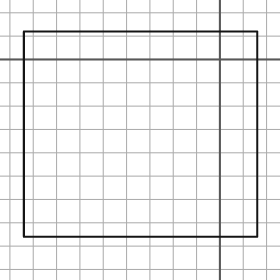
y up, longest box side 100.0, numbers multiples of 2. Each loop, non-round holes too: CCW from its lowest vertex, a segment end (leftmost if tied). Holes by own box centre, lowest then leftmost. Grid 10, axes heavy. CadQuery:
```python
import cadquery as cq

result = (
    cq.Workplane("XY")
    .moveTo(-84.0, -76.0)
    .lineTo(16.0, -76.0)
    .lineTo(16.0, 12.0)
    .lineTo(-84.0, 12.0)
    .close()
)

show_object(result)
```